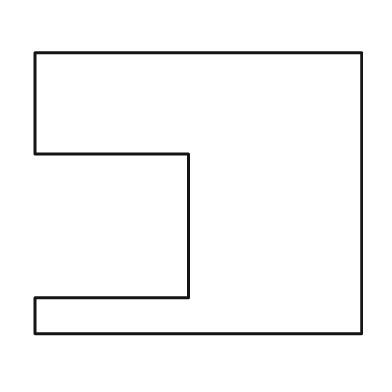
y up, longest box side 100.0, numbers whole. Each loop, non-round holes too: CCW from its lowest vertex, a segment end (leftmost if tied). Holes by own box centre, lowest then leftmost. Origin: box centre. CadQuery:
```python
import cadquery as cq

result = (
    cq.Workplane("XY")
    .moveTo(-50.0, -43.0)
    .lineTo(50.0, -43.0)
    .lineTo(50.0, 43.0)
    .lineTo(-50.0, 43.0)
    .lineTo(-50.0, 12.0)
    .lineTo(-3.0, 12.0)
    .lineTo(-3.0, -32.0)
    .lineTo(-50.0, -32.0)
    .close()
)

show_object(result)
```